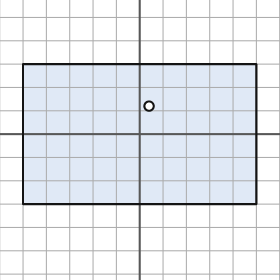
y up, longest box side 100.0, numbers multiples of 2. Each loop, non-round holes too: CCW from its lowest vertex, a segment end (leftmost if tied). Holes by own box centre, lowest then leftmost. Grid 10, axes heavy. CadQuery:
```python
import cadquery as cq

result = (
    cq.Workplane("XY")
    .moveTo(-50.0, -30.0)
    .lineTo(50.0, -30.0)
    .lineTo(50.0, 30.0)
    .lineTo(-50.0, 30.0)
    .close()
    .moveTo(4.0, 12.0)
    .circle(2.0)
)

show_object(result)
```